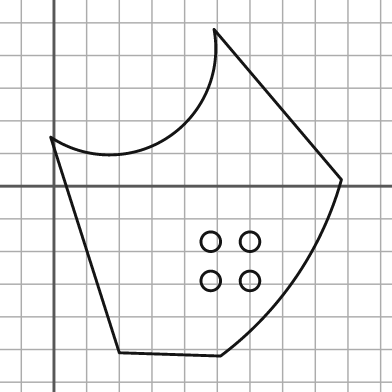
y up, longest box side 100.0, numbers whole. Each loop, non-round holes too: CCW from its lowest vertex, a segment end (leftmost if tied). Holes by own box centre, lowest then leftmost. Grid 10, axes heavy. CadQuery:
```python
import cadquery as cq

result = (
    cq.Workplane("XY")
    .moveTo(51.0, -52.0)
    .threePointArc((74.0, -28.0), (88.0, 2.0))
    .lineTo(49.0, 48.0)
    .threePointArc((35.0, 15.0), (-1.0, 15.0))
    .lineTo(20.0, -51.0)
    .close()
    .moveTo(48.0, -29.0)
    .circle(3.0)
    .moveTo(60.0, -29.0)
    .circle(3.0)
    .moveTo(48.0, -17.0)
    .circle(3.0)
    .moveTo(60.0, -17.0)
    .circle(3.0)
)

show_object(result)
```